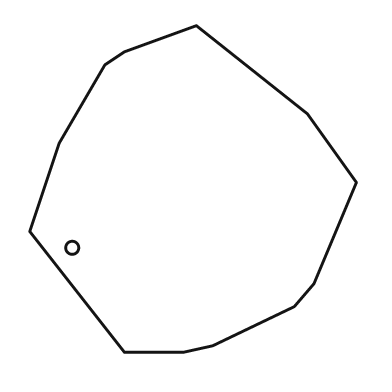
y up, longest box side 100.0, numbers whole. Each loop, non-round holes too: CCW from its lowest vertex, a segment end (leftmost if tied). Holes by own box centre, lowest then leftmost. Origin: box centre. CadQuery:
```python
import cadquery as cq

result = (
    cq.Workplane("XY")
    .moveTo(-21.0, -50.0)
    .lineTo(-3.0, -50.0)
    .lineTo(6.0, -48.0)
    .lineTo(31.0, -36.0)
    .lineTo(37.0, -29.0)
    .lineTo(50.0, 2.0)
    .lineTo(35.0, 23.0)
    .lineTo(1.0, 50.0)
    .lineTo(-21.0, 42.0)
    .lineTo(-27.0, 38.0)
    .lineTo(-41.0, 14.0)
    .lineTo(-50.0, -13.0)
    .close()
    .moveTo(-37.0, -18.0)
    .circle(2.0)
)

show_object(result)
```